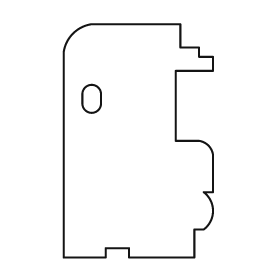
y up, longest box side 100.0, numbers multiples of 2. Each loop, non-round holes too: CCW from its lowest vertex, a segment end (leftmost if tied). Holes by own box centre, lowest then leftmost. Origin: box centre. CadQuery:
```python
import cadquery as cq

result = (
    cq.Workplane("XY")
    .moveTo(-32.0, -50.0)
    .lineTo(-14.0, -50.0)
    .lineTo(-14.0, -46.0)
    .lineTo(-4.0, -46.0)
    .lineTo(-4.0, -50.0)
    .lineTo(24.0, -50.0)
    .lineTo(24.0, -38.0)
    .lineTo(28.0, -38.0)
    .threePointArc((32.0, -30.0), (28.0, -22.0))
    .lineTo(32.0, -22.0)
    .lineTo(32.0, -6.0)
    .threePointArc((30.0, -2.0), (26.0, 0.0))
    .lineTo(16.0, 0.0)
    .lineTo(16.0, 30.0)
    .lineTo(32.0, 30.0)
    .lineTo(32.0, 36.0)
    .lineTo(26.0, 36.0)
    .lineTo(26.0, 40.0)
    .lineTo(18.0, 40.0)
    .lineTo(18.0, 50.0)
    .lineTo(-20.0, 50.0)
    .threePointArc((-28.0, 46.0), (-32.0, 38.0))
    .close()
    .moveTo(-24.0, 16.0)
    .threePointArc((-20.0, 12.0), (-16.0, 16.0))
    .lineTo(-16.0, 20.0)
    .threePointArc((-20.0, 24.0), (-24.0, 20.0))
    .close()
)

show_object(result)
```